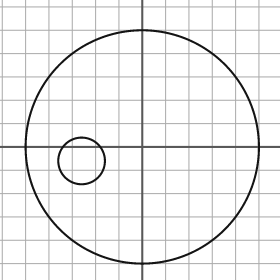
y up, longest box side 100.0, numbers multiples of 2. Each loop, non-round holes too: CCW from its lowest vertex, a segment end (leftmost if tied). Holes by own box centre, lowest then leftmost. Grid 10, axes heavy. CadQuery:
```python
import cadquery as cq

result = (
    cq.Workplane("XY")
    .moveTo(0.0, 0.0)
    .circle(50.0)
    .moveTo(-26.0, -6.0)
    .circle(10.0)
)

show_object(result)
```